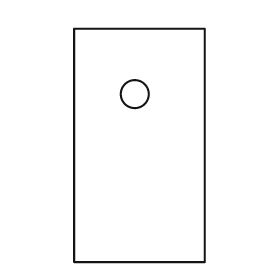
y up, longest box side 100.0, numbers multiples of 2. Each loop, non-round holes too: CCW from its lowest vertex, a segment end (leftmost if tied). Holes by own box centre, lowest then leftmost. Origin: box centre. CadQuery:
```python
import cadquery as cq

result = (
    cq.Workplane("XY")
    .moveTo(-28.0, -50.0)
    .lineTo(28.0, -50.0)
    .lineTo(28.0, 50.0)
    .lineTo(-28.0, 50.0)
    .close()
    .moveTo(-2.0, 22.0)
    .circle(6.0)
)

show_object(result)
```